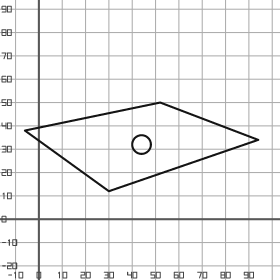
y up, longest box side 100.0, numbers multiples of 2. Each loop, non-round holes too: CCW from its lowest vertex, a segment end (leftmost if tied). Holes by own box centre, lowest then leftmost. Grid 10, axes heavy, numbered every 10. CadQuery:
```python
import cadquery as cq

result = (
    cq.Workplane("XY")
    .moveTo(30.0, 12.0)
    .lineTo(94.0, 34.0)
    .lineTo(52.0, 50.0)
    .lineTo(-6.0, 38.0)
    .close()
    .moveTo(44.0, 32.0)
    .circle(4.0)
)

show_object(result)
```